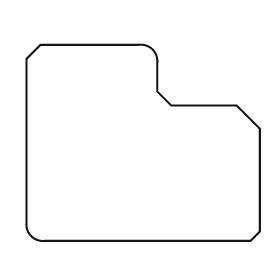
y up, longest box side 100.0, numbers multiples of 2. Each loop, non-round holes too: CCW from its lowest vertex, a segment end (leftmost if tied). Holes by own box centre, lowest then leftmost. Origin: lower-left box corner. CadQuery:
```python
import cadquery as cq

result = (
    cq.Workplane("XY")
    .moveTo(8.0, 0.0)
    .lineTo(96.0, 0.0)
    .lineTo(100.0, 4.0)
    .lineTo(100.0, 48.0)
    .lineTo(90.0, 58.0)
    .lineTo(62.0, 58.0)
    .lineTo(56.0, 64.0)
    .lineTo(56.0, 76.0)
    .threePointArc((54.0, 82.0), (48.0, 84.0))
    .lineTo(6.0, 84.0)
    .lineTo(0.0, 78.0)
    .lineTo(0.0, 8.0)
    .threePointArc((2.0, 2.0), (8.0, 0.0))
    .close()
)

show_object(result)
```